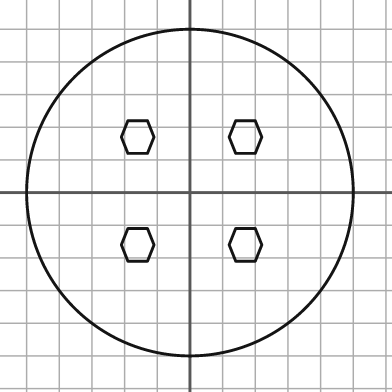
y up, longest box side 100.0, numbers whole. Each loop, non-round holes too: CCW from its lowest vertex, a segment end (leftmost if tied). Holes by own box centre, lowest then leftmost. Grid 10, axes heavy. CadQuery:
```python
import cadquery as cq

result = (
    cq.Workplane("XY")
    .moveTo(0.0, 0.0)
    .circle(50.0)
    .moveTo(-19.0, -21.0)
    .lineTo(-13.0, -21.0)
    .lineTo(-11.0, -16.0)
    .lineTo(-13.0, -11.0)
    .lineTo(-19.0, -11.0)
    .lineTo(-21.0, -16.0)
    .close()
    .moveTo(14.0, -21.0)
    .lineTo(20.0, -21.0)
    .lineTo(22.0, -16.0)
    .lineTo(20.0, -11.0)
    .lineTo(14.0, -11.0)
    .lineTo(12.0, -16.0)
    .close()
    .moveTo(-19.0, 12.0)
    .lineTo(-13.0, 12.0)
    .lineTo(-11.0, 17.0)
    .lineTo(-13.0, 22.0)
    .lineTo(-19.0, 22.0)
    .lineTo(-21.0, 17.0)
    .close()
    .moveTo(14.0, 12.0)
    .lineTo(20.0, 12.0)
    .lineTo(22.0, 17.0)
    .lineTo(20.0, 22.0)
    .lineTo(14.0, 22.0)
    .lineTo(12.0, 17.0)
    .close()
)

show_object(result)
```